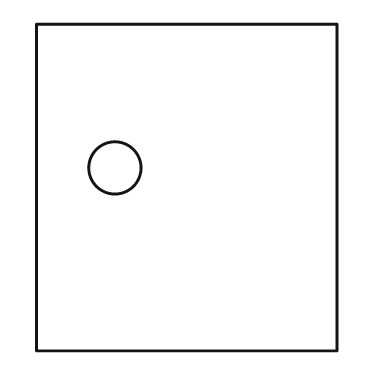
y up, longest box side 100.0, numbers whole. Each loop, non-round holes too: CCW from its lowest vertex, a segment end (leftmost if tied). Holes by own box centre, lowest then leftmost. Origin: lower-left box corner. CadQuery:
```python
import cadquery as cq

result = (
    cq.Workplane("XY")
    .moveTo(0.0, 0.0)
    .lineTo(92.0, 0.0)
    .lineTo(92.0, 100.0)
    .lineTo(0.0, 100.0)
    .close()
    .moveTo(24.0, 56.0)
    .circle(8.0)
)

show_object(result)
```